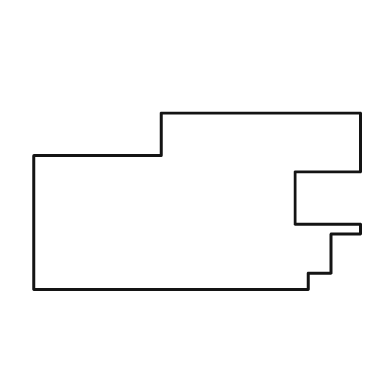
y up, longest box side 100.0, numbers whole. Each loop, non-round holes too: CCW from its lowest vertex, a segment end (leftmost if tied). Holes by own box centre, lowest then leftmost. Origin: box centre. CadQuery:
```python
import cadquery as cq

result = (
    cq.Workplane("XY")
    .moveTo(-50.0, -27.0)
    .lineTo(34.0, -27.0)
    .lineTo(34.0, -22.0)
    .lineTo(41.0, -22.0)
    .lineTo(41.0, -10.0)
    .lineTo(50.0, -10.0)
    .lineTo(50.0, -7.0)
    .lineTo(30.0, -7.0)
    .lineTo(30.0, 9.0)
    .lineTo(50.0, 9.0)
    .lineTo(50.0, 27.0)
    .lineTo(-11.0, 27.0)
    .lineTo(-11.0, 14.0)
    .lineTo(-50.0, 14.0)
    .close()
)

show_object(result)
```